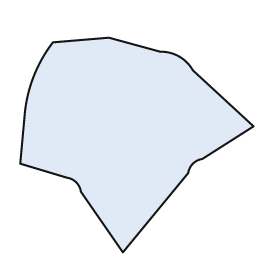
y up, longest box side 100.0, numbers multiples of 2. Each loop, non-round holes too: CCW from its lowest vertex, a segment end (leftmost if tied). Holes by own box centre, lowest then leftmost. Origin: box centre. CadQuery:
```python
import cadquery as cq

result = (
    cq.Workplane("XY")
    .moveTo(-6.0, -46.0)
    .lineTo(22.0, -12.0)
    .threePointArc((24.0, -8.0), (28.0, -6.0))
    .lineTo(50.0, 8.0)
    .lineTo(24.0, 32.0)
    .threePointArc((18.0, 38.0), (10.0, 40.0))
    .lineTo(-12.0, 46.0)
    .lineTo(-36.0, 44.0)
    .threePointArc((-44.0, 30.0), (-48.0, 14.0))
    .lineTo(-50.0, -8.0)
    .lineTo(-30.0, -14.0)
    .threePointArc((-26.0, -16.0), (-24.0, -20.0))
    .close()
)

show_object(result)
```